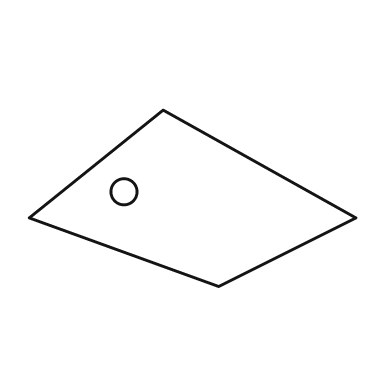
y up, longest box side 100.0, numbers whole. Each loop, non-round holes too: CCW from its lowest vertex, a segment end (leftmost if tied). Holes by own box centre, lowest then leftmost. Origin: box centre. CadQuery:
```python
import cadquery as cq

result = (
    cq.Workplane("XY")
    .moveTo(8.0, -27.0)
    .lineTo(50.0, -6.0)
    .lineTo(-9.0, 27.0)
    .lineTo(-50.0, -6.0)
    .close()
    .moveTo(-21.0, 2.0)
    .circle(4.0)
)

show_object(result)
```